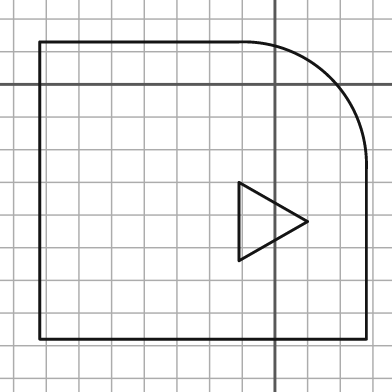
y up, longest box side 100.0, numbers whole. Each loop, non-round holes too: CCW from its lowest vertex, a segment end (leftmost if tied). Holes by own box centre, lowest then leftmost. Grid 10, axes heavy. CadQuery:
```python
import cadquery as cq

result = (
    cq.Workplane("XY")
    .moveTo(-72.0, -78.0)
    .lineTo(28.0, -78.0)
    .lineTo(28.0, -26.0)
    .threePointArc((17.0, 2.0), (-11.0, 13.0))
    .lineTo(-72.0, 13.0)
    .close()
    .moveTo(-11.0, -54.0)
    .lineTo(10.0, -42.0)
    .lineTo(-11.0, -30.0)
    .close()
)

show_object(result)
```